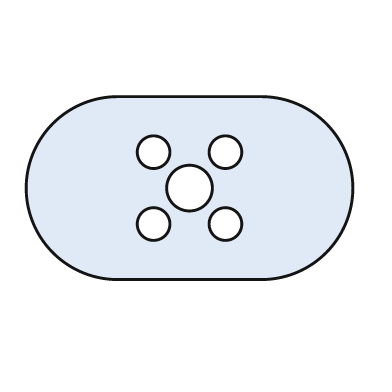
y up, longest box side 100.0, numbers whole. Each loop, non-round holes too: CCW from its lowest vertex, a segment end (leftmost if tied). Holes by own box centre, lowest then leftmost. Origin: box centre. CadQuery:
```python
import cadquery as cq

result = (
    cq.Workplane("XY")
    .moveTo(-22.0, -28.0)
    .lineTo(22.0, -28.0)
    .threePointArc((50.0, 0.0), (22.0, 28.0))
    .lineTo(-22.0, 28.0)
    .threePointArc((-50.0, 0.0), (-22.0, -28.0))
    .close()
    .moveTo(-11.0, -11.0)
    .circle(5.0)
    .moveTo(11.0, -11.0)
    .circle(5.0)
    .moveTo(0.0, 0.0)
    .circle(7.0)
    .moveTo(-11.0, 11.0)
    .circle(5.0)
    .moveTo(11.0, 11.0)
    .circle(5.0)
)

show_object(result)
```